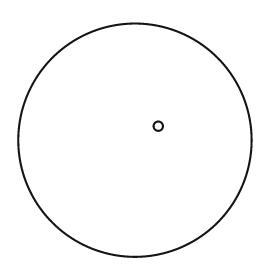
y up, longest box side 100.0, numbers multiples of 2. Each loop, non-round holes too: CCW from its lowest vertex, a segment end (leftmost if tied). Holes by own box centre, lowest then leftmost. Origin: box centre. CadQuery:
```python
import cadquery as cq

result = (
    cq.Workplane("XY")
    .moveTo(0.0, 0.0)
    .circle(50.0)
    .moveTo(10.0, 6.0)
    .circle(2.0)
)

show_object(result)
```